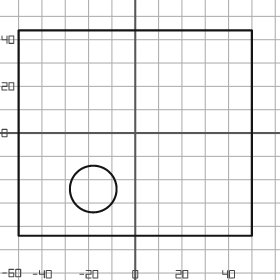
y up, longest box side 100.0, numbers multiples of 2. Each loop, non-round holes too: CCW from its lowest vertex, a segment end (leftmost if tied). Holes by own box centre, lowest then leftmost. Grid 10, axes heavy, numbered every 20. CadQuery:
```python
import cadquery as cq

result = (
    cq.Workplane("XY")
    .moveTo(-50.0, -44.0)
    .lineTo(50.0, -44.0)
    .lineTo(50.0, 44.0)
    .lineTo(-50.0, 44.0)
    .close()
    .moveTo(-18.0, -24.0)
    .circle(10.0)
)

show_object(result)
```